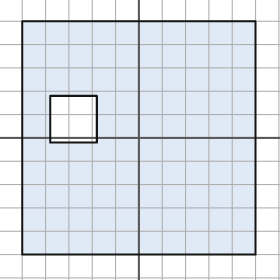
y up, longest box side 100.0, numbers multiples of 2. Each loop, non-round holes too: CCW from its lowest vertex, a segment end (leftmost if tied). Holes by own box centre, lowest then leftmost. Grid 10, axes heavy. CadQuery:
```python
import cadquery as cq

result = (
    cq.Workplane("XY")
    .moveTo(-50.0, -50.0)
    .lineTo(50.0, -50.0)
    .lineTo(50.0, 50.0)
    .lineTo(-50.0, 50.0)
    .close()
    .moveTo(-38.0, -2.0)
    .lineTo(-18.0, -2.0)
    .lineTo(-18.0, 18.0)
    .lineTo(-38.0, 18.0)
    .close()
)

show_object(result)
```